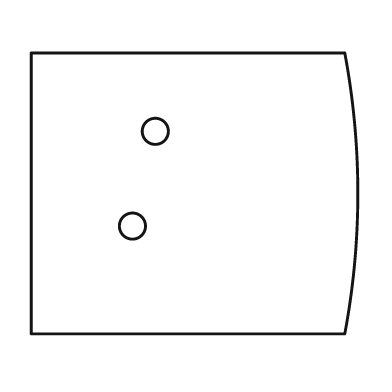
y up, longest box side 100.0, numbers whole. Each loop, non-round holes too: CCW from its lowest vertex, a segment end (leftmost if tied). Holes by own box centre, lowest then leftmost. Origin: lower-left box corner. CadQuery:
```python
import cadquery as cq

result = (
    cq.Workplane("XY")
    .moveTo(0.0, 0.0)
    .lineTo(96.0, 0.0)
    .threePointArc((100.0, 43.0), (96.0, 86.0))
    .lineTo(0.0, 86.0)
    .close()
    .moveTo(31.0, 33.0)
    .circle(4.0)
    .moveTo(38.0, 62.0)
    .circle(4.0)
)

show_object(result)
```